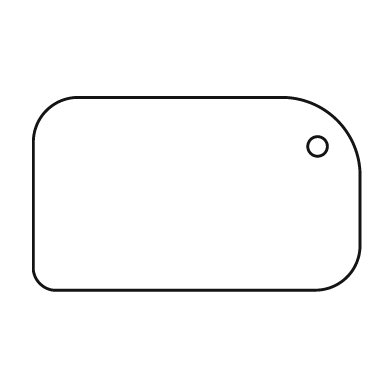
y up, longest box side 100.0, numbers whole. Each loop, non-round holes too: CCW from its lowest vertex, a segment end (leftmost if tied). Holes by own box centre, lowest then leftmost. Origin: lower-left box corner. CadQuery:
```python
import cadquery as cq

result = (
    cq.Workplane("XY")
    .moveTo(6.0, 0.0)
    .lineTo(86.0, 0.0)
    .threePointArc((96.0, 4.0), (100.0, 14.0))
    .lineTo(100.0, 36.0)
    .threePointArc((93.0, 52.0), (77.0, 59.0))
    .lineTo(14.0, 59.0)
    .threePointArc((4.0, 55.0), (0.0, 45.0))
    .lineTo(0.0, 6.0)
    .threePointArc((2.0, 2.0), (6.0, 0.0))
    .close()
    .moveTo(87.0, 44.0)
    .circle(3.0)
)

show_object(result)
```